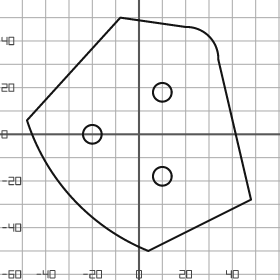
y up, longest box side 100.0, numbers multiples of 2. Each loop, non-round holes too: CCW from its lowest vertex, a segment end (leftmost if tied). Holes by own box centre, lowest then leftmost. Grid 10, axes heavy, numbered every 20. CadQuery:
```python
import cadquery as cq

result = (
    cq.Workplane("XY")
    .moveTo(4.0, -50.0)
    .lineTo(48.0, -28.0)
    .lineTo(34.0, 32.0)
    .threePointArc((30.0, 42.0), (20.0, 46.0))
    .lineTo(-8.0, 50.0)
    .lineTo(-48.0, 6.0)
    .threePointArc((-28.0, -28.0), (4.0, -50.0))
    .close()
    .moveTo(10.0, -18.0)
    .circle(4.0)
    .moveTo(-20.0, 0.0)
    .circle(4.0)
    .moveTo(10.0, 18.0)
    .circle(4.0)
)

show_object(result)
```